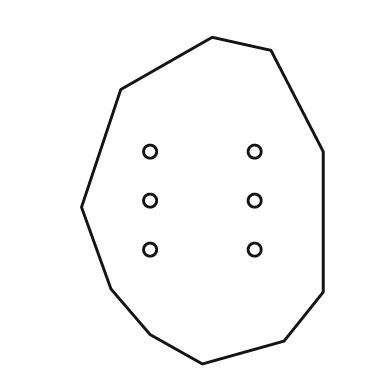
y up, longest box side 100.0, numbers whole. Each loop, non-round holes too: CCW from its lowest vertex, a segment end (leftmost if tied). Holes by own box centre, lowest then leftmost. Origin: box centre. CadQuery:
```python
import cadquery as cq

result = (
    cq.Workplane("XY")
    .moveTo(0.0, -50.0)
    .lineTo(25.0, -43.0)
    .lineTo(37.0, -28.0)
    .lineTo(37.0, 15.0)
    .lineTo(21.0, 46.0)
    .lineTo(3.0, 50.0)
    .lineTo(-25.0, 34.0)
    .lineTo(-37.0, -2.0)
    .lineTo(-28.0, -27.0)
    .lineTo(-16.0, -41.0)
    .close()
    .moveTo(-16.0, -15.0)
    .circle(2.0)
    .moveTo(16.0, -15.0)
    .circle(2.0)
    .moveTo(-16.0, 0.0)
    .circle(2.0)
    .moveTo(16.0, 0.0)
    .circle(2.0)
    .moveTo(-16.0, 15.0)
    .circle(2.0)
    .moveTo(16.0, 15.0)
    .circle(2.0)
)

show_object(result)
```